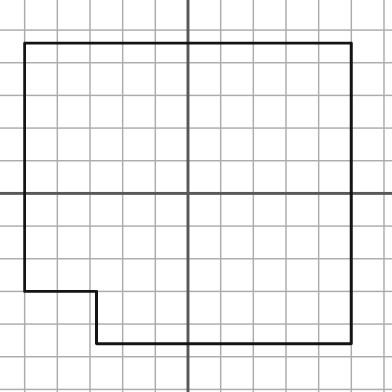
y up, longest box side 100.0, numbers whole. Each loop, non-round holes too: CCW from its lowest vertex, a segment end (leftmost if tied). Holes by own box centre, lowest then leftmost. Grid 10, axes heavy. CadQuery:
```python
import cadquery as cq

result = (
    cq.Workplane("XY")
    .moveTo(-28.0, -46.0)
    .lineTo(50.0, -46.0)
    .lineTo(50.0, 46.0)
    .lineTo(-50.0, 46.0)
    .lineTo(-50.0, -30.0)
    .lineTo(-28.0, -30.0)
    .close()
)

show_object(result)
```